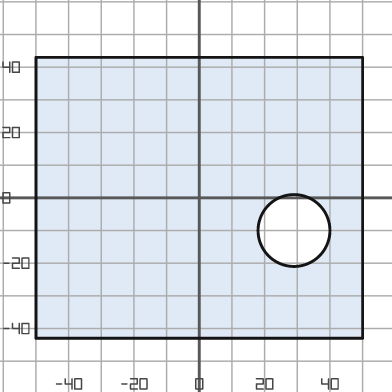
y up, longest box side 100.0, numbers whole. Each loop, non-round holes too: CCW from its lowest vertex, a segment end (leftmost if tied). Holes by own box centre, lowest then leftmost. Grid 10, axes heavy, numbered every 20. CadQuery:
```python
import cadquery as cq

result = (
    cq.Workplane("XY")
    .moveTo(-50.0, -43.0)
    .lineTo(50.0, -43.0)
    .lineTo(50.0, 43.0)
    .lineTo(-50.0, 43.0)
    .close()
    .moveTo(29.0, -10.0)
    .circle(11.0)
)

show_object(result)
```